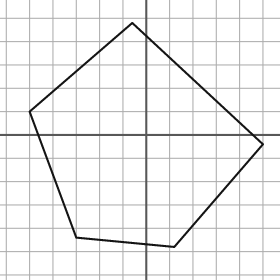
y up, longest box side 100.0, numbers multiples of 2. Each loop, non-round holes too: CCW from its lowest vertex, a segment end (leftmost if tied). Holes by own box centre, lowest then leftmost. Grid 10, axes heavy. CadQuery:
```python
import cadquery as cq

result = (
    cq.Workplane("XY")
    .moveTo(12.0, -48.0)
    .lineTo(50.0, -4.0)
    .lineTo(-6.0, 48.0)
    .lineTo(-50.0, 10.0)
    .lineTo(-30.0, -44.0)
    .close()
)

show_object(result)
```